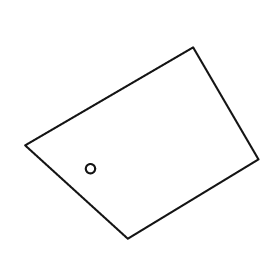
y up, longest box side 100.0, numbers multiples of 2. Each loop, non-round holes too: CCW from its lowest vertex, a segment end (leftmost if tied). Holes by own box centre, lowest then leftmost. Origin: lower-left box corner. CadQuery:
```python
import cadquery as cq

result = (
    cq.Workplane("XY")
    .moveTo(44.0, 0.0)
    .lineTo(100.0, 34.0)
    .lineTo(72.0, 82.0)
    .lineTo(0.0, 40.0)
    .close()
    .moveTo(28.0, 30.0)
    .circle(2.0)
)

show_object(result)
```